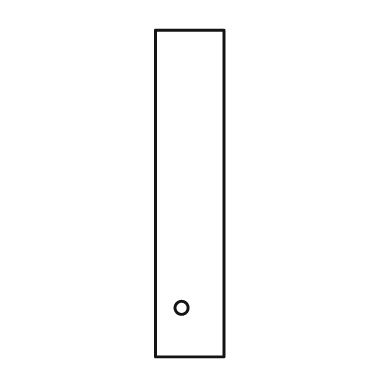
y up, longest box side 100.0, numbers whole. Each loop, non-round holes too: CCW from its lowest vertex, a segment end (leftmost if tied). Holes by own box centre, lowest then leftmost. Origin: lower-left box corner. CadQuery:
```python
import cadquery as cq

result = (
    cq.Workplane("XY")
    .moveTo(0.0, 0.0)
    .lineTo(21.0, 0.0)
    .lineTo(21.0, 100.0)
    .lineTo(0.0, 100.0)
    .close()
    .moveTo(8.0, 15.0)
    .circle(2.0)
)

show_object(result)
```